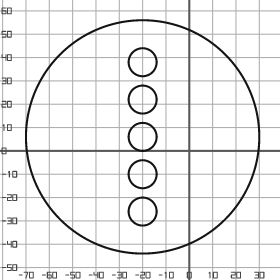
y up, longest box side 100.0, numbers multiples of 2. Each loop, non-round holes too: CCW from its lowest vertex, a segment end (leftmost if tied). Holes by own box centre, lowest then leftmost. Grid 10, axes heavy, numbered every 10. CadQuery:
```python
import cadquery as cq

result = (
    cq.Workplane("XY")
    .moveTo(-20.0, 6.0)
    .circle(50.0)
    .moveTo(-20.0, -26.0)
    .circle(6.0)
    .moveTo(-20.0, -10.0)
    .circle(6.0)
    .moveTo(-20.0, 6.0)
    .circle(6.0)
    .moveTo(-20.0, 22.0)
    .circle(6.0)
    .moveTo(-20.0, 38.0)
    .circle(6.0)
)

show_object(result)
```